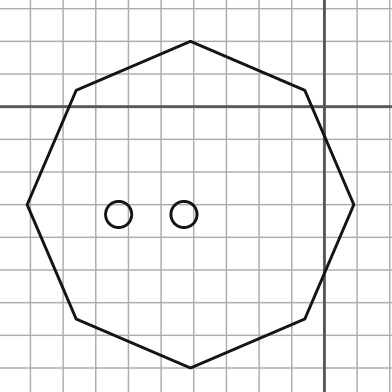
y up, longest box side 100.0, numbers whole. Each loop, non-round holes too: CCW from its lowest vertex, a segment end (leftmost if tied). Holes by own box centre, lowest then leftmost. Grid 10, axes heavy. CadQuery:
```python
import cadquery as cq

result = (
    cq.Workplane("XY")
    .moveTo(-41.0, -80.0)
    .lineTo(-6.0, -65.0)
    .lineTo(9.0, -30.0)
    .lineTo(-6.0, 5.0)
    .lineTo(-41.0, 20.0)
    .lineTo(-76.0, 5.0)
    .lineTo(-91.0, -30.0)
    .lineTo(-76.0, -65.0)
    .close()
    .moveTo(-63.0, -33.0)
    .circle(4.0)
    .moveTo(-43.0, -33.0)
    .circle(4.0)
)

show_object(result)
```